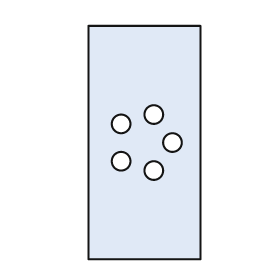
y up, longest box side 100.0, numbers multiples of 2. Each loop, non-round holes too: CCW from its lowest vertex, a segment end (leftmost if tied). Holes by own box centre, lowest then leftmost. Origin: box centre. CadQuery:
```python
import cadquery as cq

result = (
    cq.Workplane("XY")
    .moveTo(-24.0, -50.0)
    .lineTo(24.0, -50.0)
    .lineTo(24.0, 50.0)
    .lineTo(-24.0, 50.0)
    .close()
    .moveTo(4.0, -12.0)
    .circle(4.0)
    .moveTo(-10.0, -8.0)
    .circle(4.0)
    .moveTo(12.0, 0.0)
    .circle(4.0)
    .moveTo(-10.0, 8.0)
    .circle(4.0)
    .moveTo(4.0, 12.0)
    .circle(4.0)
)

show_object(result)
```